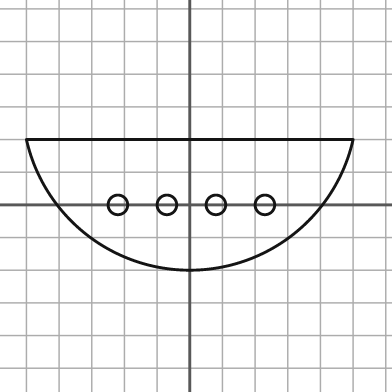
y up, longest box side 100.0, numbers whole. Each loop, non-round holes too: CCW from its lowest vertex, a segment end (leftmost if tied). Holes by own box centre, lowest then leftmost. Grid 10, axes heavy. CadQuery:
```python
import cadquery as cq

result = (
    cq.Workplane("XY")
    .moveTo(-50.0, 20.0)
    .threePointArc((0.0, -20.0), (50.0, 20.0))
    .close()
    .moveTo(-22.0, 0.0)
    .circle(3.0)
    .moveTo(-7.0, 0.0)
    .circle(3.0)
    .moveTo(8.0, 0.0)
    .circle(3.0)
    .moveTo(23.0, 0.0)
    .circle(3.0)
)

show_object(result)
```